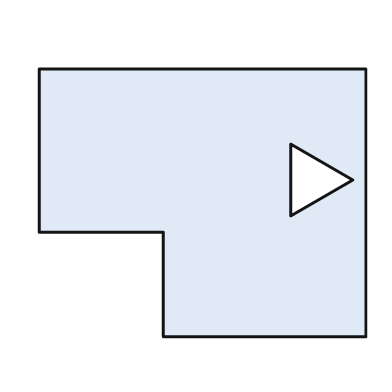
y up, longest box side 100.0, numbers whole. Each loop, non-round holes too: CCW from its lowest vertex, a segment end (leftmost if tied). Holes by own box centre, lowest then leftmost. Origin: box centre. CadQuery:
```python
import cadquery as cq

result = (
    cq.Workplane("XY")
    .moveTo(-12.0, -41.0)
    .lineTo(50.0, -41.0)
    .lineTo(50.0, 41.0)
    .lineTo(-50.0, 41.0)
    .lineTo(-50.0, -9.0)
    .lineTo(-12.0, -9.0)
    .close()
    .moveTo(27.0, -4.0)
    .lineTo(46.0, 7.0)
    .lineTo(27.0, 18.0)
    .close()
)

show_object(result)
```